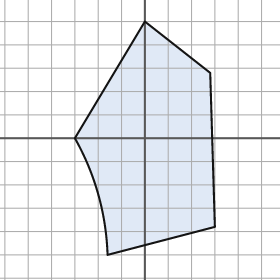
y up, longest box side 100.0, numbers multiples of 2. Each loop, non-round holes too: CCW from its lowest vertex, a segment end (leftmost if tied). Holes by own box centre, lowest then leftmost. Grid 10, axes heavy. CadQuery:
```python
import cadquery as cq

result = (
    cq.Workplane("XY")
    .moveTo(-16.0, -50.0)
    .lineTo(30.0, -38.0)
    .lineTo(28.0, 28.0)
    .lineTo(0.0, 50.0)
    .lineTo(-30.0, 0.0)
    .threePointArc((-20.0, -24.0), (-16.0, -50.0))
    .close()
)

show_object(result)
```